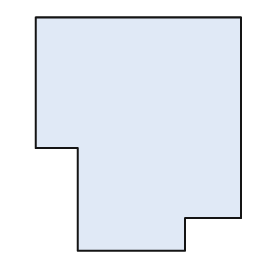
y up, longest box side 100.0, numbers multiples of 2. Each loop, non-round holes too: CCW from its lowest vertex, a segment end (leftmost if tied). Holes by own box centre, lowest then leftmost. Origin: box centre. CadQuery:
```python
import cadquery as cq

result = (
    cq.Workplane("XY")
    .moveTo(-26.0, -50.0)
    .lineTo(20.0, -50.0)
    .lineTo(20.0, -36.0)
    .lineTo(44.0, -36.0)
    .lineTo(44.0, 50.0)
    .lineTo(-44.0, 50.0)
    .lineTo(-44.0, -6.0)
    .lineTo(-26.0, -6.0)
    .close()
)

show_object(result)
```